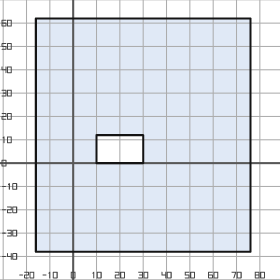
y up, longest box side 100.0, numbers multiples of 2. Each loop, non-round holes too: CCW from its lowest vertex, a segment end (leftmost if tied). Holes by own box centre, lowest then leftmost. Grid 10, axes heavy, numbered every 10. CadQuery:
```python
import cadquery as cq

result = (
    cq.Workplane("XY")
    .moveTo(-16.0, -38.0)
    .lineTo(76.0, -38.0)
    .lineTo(76.0, 62.0)
    .lineTo(-16.0, 62.0)
    .close()
    .moveTo(10.0, 0.0)
    .lineTo(30.0, 0.0)
    .lineTo(30.0, 12.0)
    .lineTo(10.0, 12.0)
    .close()
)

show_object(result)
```